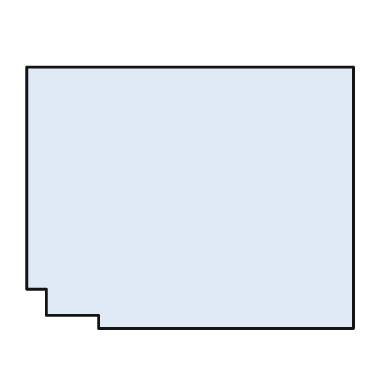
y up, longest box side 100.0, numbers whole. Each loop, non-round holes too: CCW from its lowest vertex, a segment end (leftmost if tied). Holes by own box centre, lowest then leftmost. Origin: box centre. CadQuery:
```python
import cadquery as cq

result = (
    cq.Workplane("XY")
    .moveTo(-28.0, -40.0)
    .lineTo(50.0, -40.0)
    .lineTo(50.0, 40.0)
    .lineTo(-50.0, 40.0)
    .lineTo(-50.0, -28.0)
    .lineTo(-44.0, -28.0)
    .lineTo(-44.0, -36.0)
    .lineTo(-28.0, -36.0)
    .close()
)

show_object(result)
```